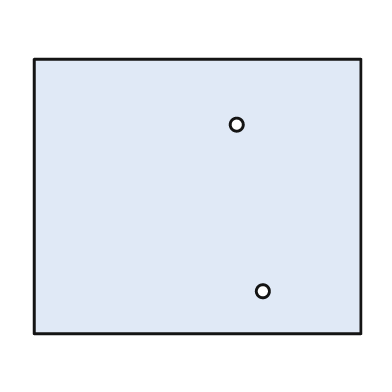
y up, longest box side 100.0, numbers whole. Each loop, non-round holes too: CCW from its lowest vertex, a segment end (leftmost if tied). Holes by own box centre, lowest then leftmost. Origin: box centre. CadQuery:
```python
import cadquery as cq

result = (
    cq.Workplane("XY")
    .moveTo(-50.0, -42.0)
    .lineTo(50.0, -42.0)
    .lineTo(50.0, 42.0)
    .lineTo(-50.0, 42.0)
    .close()
    .moveTo(20.0, -29.0)
    .circle(2.0)
    .moveTo(12.0, 22.0)
    .circle(2.0)
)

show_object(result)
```